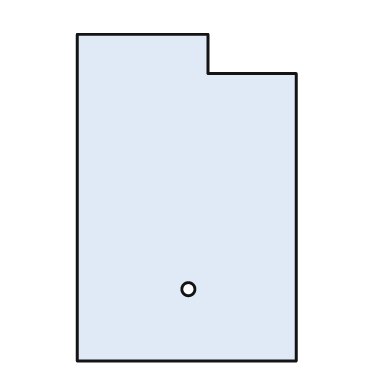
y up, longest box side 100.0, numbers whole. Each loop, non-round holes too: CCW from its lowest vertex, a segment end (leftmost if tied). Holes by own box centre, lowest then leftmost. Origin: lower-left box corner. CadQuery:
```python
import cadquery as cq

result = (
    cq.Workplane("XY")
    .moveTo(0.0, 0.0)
    .lineTo(67.0, 0.0)
    .lineTo(67.0, 88.0)
    .lineTo(40.0, 88.0)
    .lineTo(40.0, 100.0)
    .lineTo(0.0, 100.0)
    .close()
    .moveTo(34.0, 22.0)
    .circle(2.0)
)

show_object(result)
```